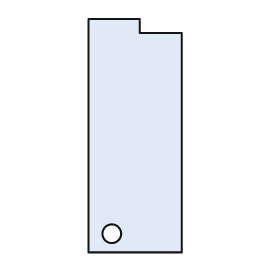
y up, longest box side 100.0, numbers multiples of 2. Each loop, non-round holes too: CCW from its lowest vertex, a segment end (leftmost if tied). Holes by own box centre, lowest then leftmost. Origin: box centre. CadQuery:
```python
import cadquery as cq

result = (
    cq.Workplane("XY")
    .moveTo(-20.0, -50.0)
    .lineTo(20.0, -50.0)
    .lineTo(20.0, 44.0)
    .lineTo(2.0, 44.0)
    .lineTo(2.0, 50.0)
    .lineTo(-20.0, 50.0)
    .close()
    .moveTo(-10.0, -42.0)
    .circle(4.0)
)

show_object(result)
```